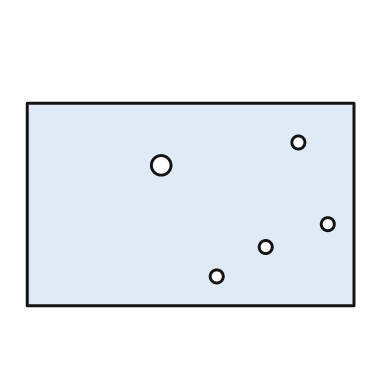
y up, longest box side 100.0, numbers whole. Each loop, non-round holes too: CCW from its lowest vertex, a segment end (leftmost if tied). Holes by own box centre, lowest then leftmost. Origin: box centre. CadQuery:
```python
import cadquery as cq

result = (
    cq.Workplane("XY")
    .moveTo(-50.0, -31.0)
    .lineTo(50.0, -31.0)
    .lineTo(50.0, 31.0)
    .lineTo(-50.0, 31.0)
    .close()
    .moveTo(8.0, -22.0)
    .circle(2.0)
    .moveTo(23.0, -13.0)
    .circle(2.0)
    .moveTo(42.0, -6.0)
    .circle(2.0)
    .moveTo(-9.0, 12.0)
    .circle(3.0)
    .moveTo(33.0, 19.0)
    .circle(2.0)
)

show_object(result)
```